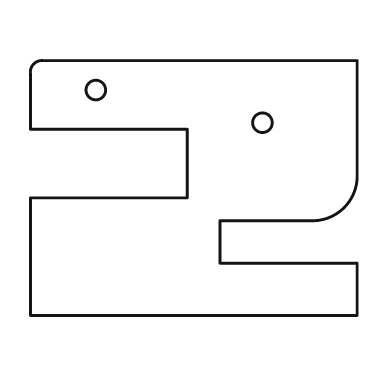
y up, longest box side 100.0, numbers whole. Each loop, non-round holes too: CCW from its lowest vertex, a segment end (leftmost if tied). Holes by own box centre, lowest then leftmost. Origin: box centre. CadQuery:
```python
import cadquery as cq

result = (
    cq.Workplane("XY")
    .moveTo(-50.0, -39.0)
    .lineTo(50.0, -39.0)
    .lineTo(50.0, -23.0)
    .lineTo(8.0, -23.0)
    .lineTo(8.0, -10.0)
    .lineTo(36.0, -10.0)
    .threePointArc((46.0, -6.0), (50.0, 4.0))
    .lineTo(50.0, 39.0)
    .lineTo(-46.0, 39.0)
    .threePointArc((-49.0, 38.0), (-50.0, 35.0))
    .lineTo(-50.0, 18.0)
    .lineTo(-2.0, 18.0)
    .lineTo(-2.0, -3.0)
    .lineTo(-50.0, -3.0)
    .close()
    .moveTo(21.0, 20.0)
    .circle(3.0)
    .moveTo(-30.0, 30.0)
    .circle(3.0)
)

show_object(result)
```